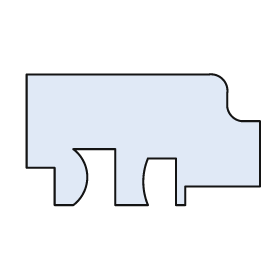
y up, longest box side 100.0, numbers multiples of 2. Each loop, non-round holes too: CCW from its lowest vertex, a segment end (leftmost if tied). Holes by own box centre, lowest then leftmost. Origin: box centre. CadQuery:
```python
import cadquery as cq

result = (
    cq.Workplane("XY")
    .moveTo(-38.0, -28.0)
    .lineTo(-30.0, -28.0)
    .threePointArc((-24.0, -16.0), (-30.0, -4.0))
    .lineTo(-12.0, -4.0)
    .lineTo(-12.0, -28.0)
    .lineTo(2.0, -28.0)
    .threePointArc((0.0, -18.0), (2.0, -8.0))
    .lineTo(14.0, -8.0)
    .lineTo(14.0, -28.0)
    .lineTo(18.0, -28.0)
    .lineTo(18.0, -20.0)
    .lineTo(50.0, -20.0)
    .lineTo(50.0, 8.0)
    .lineTo(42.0, 8.0)
    .threePointArc((38.0, 10.0), (36.0, 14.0))
    .lineTo(36.0, 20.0)
    .threePointArc((34.0, 26.0), (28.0, 28.0))
    .lineTo(-50.0, 28.0)
    .lineTo(-50.0, -12.0)
    .lineTo(-38.0, -12.0)
    .close()
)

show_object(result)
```